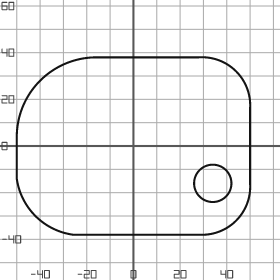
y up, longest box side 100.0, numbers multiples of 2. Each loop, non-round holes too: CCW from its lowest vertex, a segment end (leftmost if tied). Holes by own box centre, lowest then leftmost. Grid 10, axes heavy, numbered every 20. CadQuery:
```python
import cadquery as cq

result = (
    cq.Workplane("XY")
    .moveTo(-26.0, -38.0)
    .lineTo(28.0, -38.0)
    .threePointArc((44.0, -32.0), (50.0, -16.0))
    .lineTo(50.0, 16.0)
    .threePointArc((44.0, 32.0), (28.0, 38.0))
    .lineTo(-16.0, 38.0)
    .threePointArc((-40.0, 28.0), (-50.0, 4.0))
    .lineTo(-50.0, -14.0)
    .threePointArc((-42.0, -30.0), (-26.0, -38.0))
    .close()
    .moveTo(34.0, -16.0)
    .circle(8.0)
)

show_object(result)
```